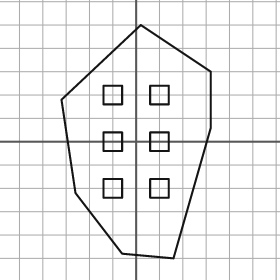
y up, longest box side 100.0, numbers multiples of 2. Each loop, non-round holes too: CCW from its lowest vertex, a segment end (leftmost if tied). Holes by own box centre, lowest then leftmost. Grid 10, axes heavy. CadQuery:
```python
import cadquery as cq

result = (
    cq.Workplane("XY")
    .moveTo(16.0, -50.0)
    .lineTo(32.0, 6.0)
    .lineTo(32.0, 30.0)
    .lineTo(2.0, 50.0)
    .lineTo(-32.0, 18.0)
    .lineTo(-26.0, -22.0)
    .lineTo(-6.0, -48.0)
    .close()
    .moveTo(-14.0, -24.0)
    .lineTo(-6.0, -24.0)
    .lineTo(-6.0, -16.0)
    .lineTo(-14.0, -16.0)
    .close()
    .moveTo(6.0, -24.0)
    .lineTo(14.0, -24.0)
    .lineTo(14.0, -16.0)
    .lineTo(6.0, -16.0)
    .close()
    .moveTo(-14.0, -4.0)
    .lineTo(-6.0, -4.0)
    .lineTo(-6.0, 4.0)
    .lineTo(-14.0, 4.0)
    .close()
    .moveTo(6.0, -4.0)
    .lineTo(14.0, -4.0)
    .lineTo(14.0, 4.0)
    .lineTo(6.0, 4.0)
    .close()
    .moveTo(-14.0, 16.0)
    .lineTo(-6.0, 16.0)
    .lineTo(-6.0, 24.0)
    .lineTo(-14.0, 24.0)
    .close()
    .moveTo(6.0, 16.0)
    .lineTo(14.0, 16.0)
    .lineTo(14.0, 24.0)
    .lineTo(6.0, 24.0)
    .close()
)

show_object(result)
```